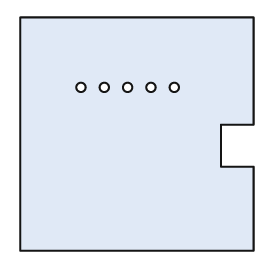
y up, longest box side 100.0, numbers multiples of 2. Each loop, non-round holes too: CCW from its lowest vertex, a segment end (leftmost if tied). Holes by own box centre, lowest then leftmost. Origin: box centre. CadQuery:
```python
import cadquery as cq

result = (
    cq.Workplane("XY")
    .moveTo(-50.0, -50.0)
    .lineTo(50.0, -50.0)
    .lineTo(50.0, -14.0)
    .lineTo(36.0, -14.0)
    .lineTo(36.0, 4.0)
    .lineTo(50.0, 4.0)
    .lineTo(50.0, 50.0)
    .lineTo(-50.0, 50.0)
    .close()
    .moveTo(-24.0, 20.0)
    .circle(2.0)
    .moveTo(-14.0, 20.0)
    .circle(2.0)
    .moveTo(-4.0, 20.0)
    .circle(2.0)
    .moveTo(6.0, 20.0)
    .circle(2.0)
    .moveTo(16.0, 20.0)
    .circle(2.0)
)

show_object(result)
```